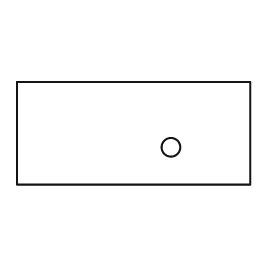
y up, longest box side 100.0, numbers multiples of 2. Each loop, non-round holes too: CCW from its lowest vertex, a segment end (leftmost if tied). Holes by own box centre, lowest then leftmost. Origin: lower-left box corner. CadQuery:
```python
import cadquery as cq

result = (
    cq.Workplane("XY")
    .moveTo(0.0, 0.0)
    .lineTo(100.0, 0.0)
    .lineTo(100.0, 44.0)
    .lineTo(0.0, 44.0)
    .close()
    .moveTo(66.0, 16.0)
    .circle(4.0)
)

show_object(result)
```